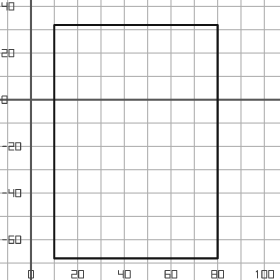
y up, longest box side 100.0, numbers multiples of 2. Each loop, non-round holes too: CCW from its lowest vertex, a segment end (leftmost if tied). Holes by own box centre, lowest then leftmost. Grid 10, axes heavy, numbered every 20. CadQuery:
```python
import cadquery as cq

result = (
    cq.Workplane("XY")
    .moveTo(10.0, -68.0)
    .lineTo(80.0, -68.0)
    .lineTo(80.0, 32.0)
    .lineTo(10.0, 32.0)
    .close()
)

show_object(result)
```